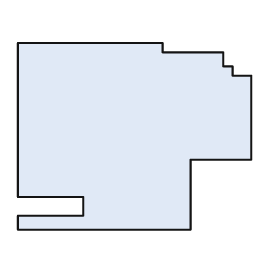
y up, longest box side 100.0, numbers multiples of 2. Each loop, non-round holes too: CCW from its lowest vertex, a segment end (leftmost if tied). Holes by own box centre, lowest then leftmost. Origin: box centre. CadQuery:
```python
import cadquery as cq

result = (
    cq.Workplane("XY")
    .moveTo(-50.0, -40.0)
    .lineTo(24.0, -40.0)
    .lineTo(24.0, -10.0)
    .lineTo(50.0, -10.0)
    .lineTo(50.0, 26.0)
    .lineTo(42.0, 26.0)
    .lineTo(42.0, 30.0)
    .lineTo(38.0, 30.0)
    .lineTo(38.0, 36.0)
    .lineTo(12.0, 36.0)
    .lineTo(12.0, 40.0)
    .lineTo(-50.0, 40.0)
    .lineTo(-50.0, -26.0)
    .lineTo(-22.0, -26.0)
    .lineTo(-22.0, -34.0)
    .lineTo(-50.0, -34.0)
    .close()
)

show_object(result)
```